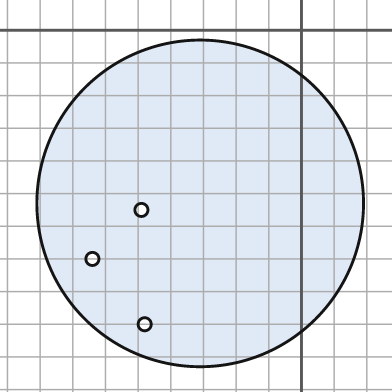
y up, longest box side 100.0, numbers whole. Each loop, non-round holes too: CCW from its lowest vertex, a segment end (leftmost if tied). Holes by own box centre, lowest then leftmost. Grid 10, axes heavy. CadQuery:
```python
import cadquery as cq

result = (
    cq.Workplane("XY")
    .moveTo(-31.0, -53.0)
    .circle(50.0)
    .moveTo(-48.0, -90.0)
    .circle(2.0)
    .moveTo(-64.0, -70.0)
    .circle(2.0)
    .moveTo(-49.0, -55.0)
    .circle(2.0)
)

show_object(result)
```